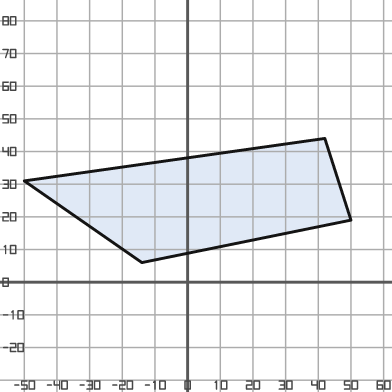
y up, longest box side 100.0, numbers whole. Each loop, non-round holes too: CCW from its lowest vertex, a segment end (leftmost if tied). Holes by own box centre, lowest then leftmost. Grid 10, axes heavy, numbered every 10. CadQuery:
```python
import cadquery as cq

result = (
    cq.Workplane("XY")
    .moveTo(-14.0, 6.0)
    .lineTo(50.0, 19.0)
    .lineTo(42.0, 44.0)
    .lineTo(-50.0, 31.0)
    .close()
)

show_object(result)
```